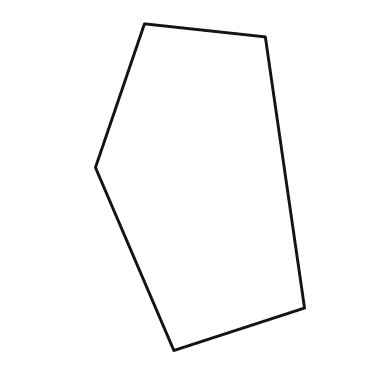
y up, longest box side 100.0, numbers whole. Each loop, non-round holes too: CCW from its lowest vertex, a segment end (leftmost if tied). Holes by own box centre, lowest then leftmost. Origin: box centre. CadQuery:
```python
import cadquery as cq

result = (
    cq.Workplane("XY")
    .moveTo(-8.0, -50.0)
    .lineTo(32.0, -37.0)
    .lineTo(20.0, 46.0)
    .lineTo(-17.0, 50.0)
    .lineTo(-32.0, 6.0)
    .close()
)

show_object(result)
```